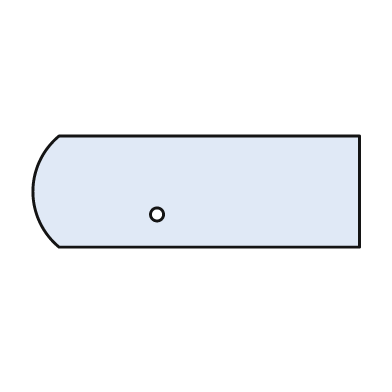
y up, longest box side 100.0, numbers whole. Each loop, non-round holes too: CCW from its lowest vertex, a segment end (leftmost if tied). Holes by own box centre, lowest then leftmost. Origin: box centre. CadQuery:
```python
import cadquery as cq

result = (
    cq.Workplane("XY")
    .moveTo(-42.0, -17.0)
    .lineTo(50.0, -17.0)
    .lineTo(50.0, 17.0)
    .lineTo(-42.0, 17.0)
    .threePointArc((-50.0, 0.0), (-42.0, -17.0))
    .close()
    .moveTo(-12.0, -7.0)
    .circle(2.0)
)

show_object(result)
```